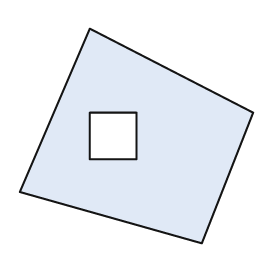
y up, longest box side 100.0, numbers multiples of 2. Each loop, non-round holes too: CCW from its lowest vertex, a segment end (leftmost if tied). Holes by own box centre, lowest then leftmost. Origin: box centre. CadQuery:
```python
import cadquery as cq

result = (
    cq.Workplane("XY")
    .moveTo(28.0, -46.0)
    .lineTo(50.0, 10.0)
    .lineTo(-20.0, 46.0)
    .lineTo(-50.0, -24.0)
    .close()
    .moveTo(-20.0, -10.0)
    .lineTo(0.0, -10.0)
    .lineTo(0.0, 10.0)
    .lineTo(-20.0, 10.0)
    .close()
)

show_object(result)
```